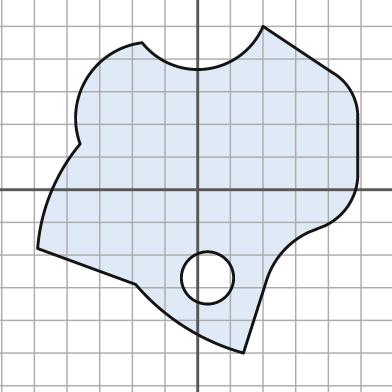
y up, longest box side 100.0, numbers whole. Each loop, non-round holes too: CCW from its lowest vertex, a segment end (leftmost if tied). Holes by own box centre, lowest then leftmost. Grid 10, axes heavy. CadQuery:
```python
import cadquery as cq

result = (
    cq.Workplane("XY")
    .moveTo(14.0, -50.0)
    .lineTo(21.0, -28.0)
    .threePointArc((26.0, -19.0), (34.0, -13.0))
    .lineTo(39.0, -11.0)
    .threePointArc((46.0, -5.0), (49.0, 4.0))
    .lineTo(49.0, 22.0)
    .threePointArc((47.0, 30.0), (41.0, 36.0))
    .lineTo(20.0, 50.0)
    .threePointArc((3.0, 37.0), (-17.0, 45.0))
    .threePointArc((-34.0, 34.0), (-36.0, 14.0))
    .threePointArc((-45.0, -1.0), (-49.0, -18.0))
    .lineTo(-19.0, -29.0)
    .threePointArc((-4.0, -42.0), (14.0, -50.0))
    .close()
    .moveTo(3.0, -27.0)
    .circle(8.0)
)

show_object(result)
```